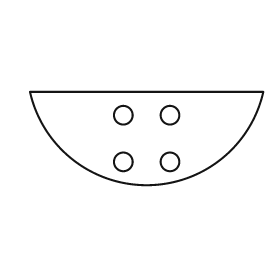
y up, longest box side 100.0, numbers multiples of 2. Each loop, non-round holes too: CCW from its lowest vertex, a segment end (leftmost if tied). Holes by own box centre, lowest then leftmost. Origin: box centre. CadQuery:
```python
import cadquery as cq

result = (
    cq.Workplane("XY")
    .moveTo(-50.0, 20.0)
    .threePointArc((0.0, -20.0), (50.0, 20.0))
    .close()
    .moveTo(-10.0, -10.0)
    .circle(4.0)
    .moveTo(10.0, -10.0)
    .circle(4.0)
    .moveTo(-10.0, 10.0)
    .circle(4.0)
    .moveTo(10.0, 10.0)
    .circle(4.0)
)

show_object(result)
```